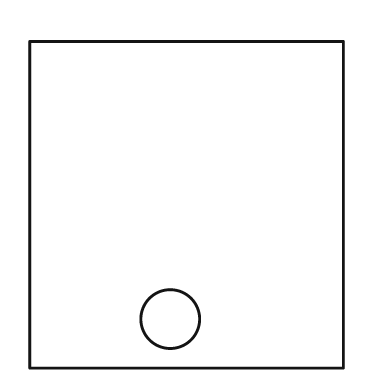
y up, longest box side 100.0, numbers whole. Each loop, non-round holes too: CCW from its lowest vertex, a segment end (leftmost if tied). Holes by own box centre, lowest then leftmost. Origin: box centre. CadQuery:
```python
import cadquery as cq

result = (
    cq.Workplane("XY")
    .moveTo(-48.0, -50.0)
    .lineTo(48.0, -50.0)
    .lineTo(48.0, 50.0)
    .lineTo(-48.0, 50.0)
    .close()
    .moveTo(-5.0, -35.0)
    .circle(9.0)
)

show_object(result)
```